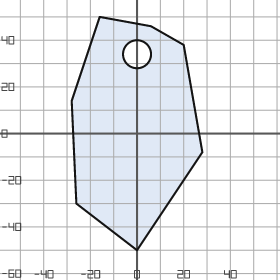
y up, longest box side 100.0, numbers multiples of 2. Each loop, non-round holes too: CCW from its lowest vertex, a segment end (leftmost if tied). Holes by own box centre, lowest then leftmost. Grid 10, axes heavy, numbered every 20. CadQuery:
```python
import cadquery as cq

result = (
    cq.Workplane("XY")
    .moveTo(0.0, -50.0)
    .lineTo(28.0, -8.0)
    .lineTo(20.0, 38.0)
    .lineTo(6.0, 46.0)
    .lineTo(-16.0, 50.0)
    .lineTo(-28.0, 14.0)
    .lineTo(-26.0, -30.0)
    .close()
    .moveTo(0.0, 34.0)
    .circle(6.0)
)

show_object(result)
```